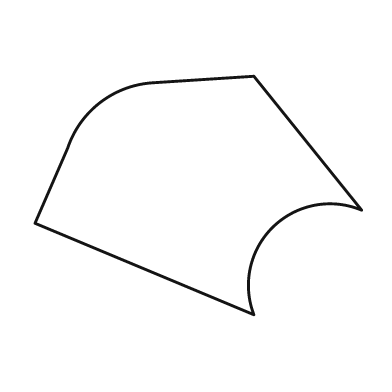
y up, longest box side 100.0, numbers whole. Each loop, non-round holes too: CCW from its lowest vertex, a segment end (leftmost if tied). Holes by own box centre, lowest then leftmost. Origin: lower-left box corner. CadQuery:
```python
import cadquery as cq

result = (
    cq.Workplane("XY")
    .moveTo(67.0, 0.0)
    .threePointArc((73.0, 27.0), (100.0, 32.0))
    .lineTo(67.0, 73.0)
    .lineTo(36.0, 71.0)
    .threePointArc((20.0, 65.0), (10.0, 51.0))
    .lineTo(0.0, 28.0)
    .close()
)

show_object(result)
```